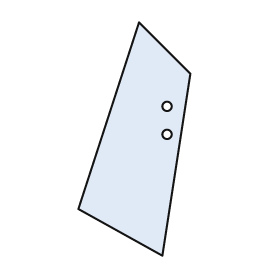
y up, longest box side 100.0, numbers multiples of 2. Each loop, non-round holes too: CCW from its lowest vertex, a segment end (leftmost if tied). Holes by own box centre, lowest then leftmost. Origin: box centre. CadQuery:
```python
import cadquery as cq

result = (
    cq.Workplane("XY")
    .moveTo(12.0, -50.0)
    .lineTo(24.0, 28.0)
    .lineTo(2.0, 50.0)
    .lineTo(-24.0, -30.0)
    .close()
    .moveTo(14.0, 2.0)
    .circle(2.0)
    .moveTo(14.0, 14.0)
    .circle(2.0)
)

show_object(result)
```